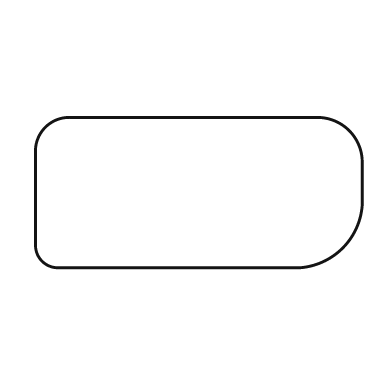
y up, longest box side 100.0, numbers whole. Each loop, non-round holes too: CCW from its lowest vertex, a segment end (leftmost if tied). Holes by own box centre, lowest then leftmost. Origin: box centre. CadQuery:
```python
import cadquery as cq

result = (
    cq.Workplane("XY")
    .moveTo(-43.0, -23.0)
    .lineTo(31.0, -23.0)
    .threePointArc((44.0, -17.0), (50.0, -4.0))
    .lineTo(50.0, 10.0)
    .threePointArc((46.0, 19.0), (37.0, 23.0))
    .lineTo(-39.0, 23.0)
    .threePointArc((-47.0, 20.0), (-50.0, 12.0))
    .lineTo(-50.0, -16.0)
    .threePointArc((-48.0, -21.0), (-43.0, -23.0))
    .close()
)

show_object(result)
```